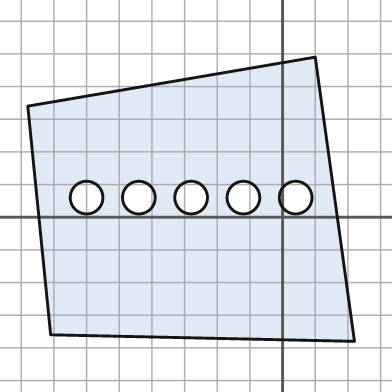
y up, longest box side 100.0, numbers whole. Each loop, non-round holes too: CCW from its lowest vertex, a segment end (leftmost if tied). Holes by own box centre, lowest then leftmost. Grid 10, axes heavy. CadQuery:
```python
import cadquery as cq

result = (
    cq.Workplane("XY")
    .moveTo(22.0, -38.0)
    .lineTo(10.0, 49.0)
    .lineTo(-78.0, 34.0)
    .lineTo(-71.0, -36.0)
    .close()
    .moveTo(-60.0, 6.0)
    .circle(5.0)
    .moveTo(-44.0, 6.0)
    .circle(5.0)
    .moveTo(-28.0, 6.0)
    .circle(5.0)
    .moveTo(-12.0, 6.0)
    .circle(5.0)
    .moveTo(4.0, 6.0)
    .circle(5.0)
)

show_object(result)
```